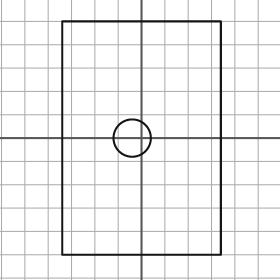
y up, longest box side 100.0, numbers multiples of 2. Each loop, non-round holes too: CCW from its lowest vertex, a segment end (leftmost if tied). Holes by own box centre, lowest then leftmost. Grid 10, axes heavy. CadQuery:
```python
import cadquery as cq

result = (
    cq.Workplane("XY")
    .moveTo(-34.0, -50.0)
    .lineTo(34.0, -50.0)
    .lineTo(34.0, 50.0)
    .lineTo(-34.0, 50.0)
    .close()
    .moveTo(-4.0, 0.0)
    .circle(8.0)
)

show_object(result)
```